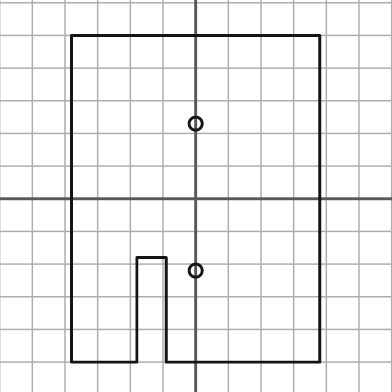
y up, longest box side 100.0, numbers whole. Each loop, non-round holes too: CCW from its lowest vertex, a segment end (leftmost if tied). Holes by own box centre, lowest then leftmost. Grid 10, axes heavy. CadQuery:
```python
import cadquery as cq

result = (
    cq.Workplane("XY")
    .moveTo(-38.0, -50.0)
    .lineTo(-18.0, -50.0)
    .lineTo(-18.0, -18.0)
    .lineTo(-9.0, -18.0)
    .lineTo(-9.0, -50.0)
    .lineTo(38.0, -50.0)
    .lineTo(38.0, 50.0)
    .lineTo(-38.0, 50.0)
    .close()
    .moveTo(0.0, -22.0)
    .circle(2.0)
    .moveTo(0.0, 23.0)
    .circle(2.0)
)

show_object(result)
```